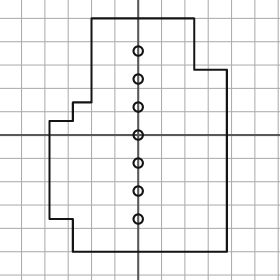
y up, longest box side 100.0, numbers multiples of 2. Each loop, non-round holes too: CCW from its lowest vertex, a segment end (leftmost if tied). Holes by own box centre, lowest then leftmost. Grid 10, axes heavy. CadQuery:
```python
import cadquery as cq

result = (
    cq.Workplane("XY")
    .moveTo(-28.0, -50.0)
    .lineTo(38.0, -50.0)
    .lineTo(38.0, 28.0)
    .lineTo(24.0, 28.0)
    .lineTo(24.0, 50.0)
    .lineTo(-20.0, 50.0)
    .lineTo(-20.0, 14.0)
    .lineTo(-28.0, 14.0)
    .lineTo(-28.0, 6.0)
    .lineTo(-38.0, 6.0)
    .lineTo(-38.0, -36.0)
    .lineTo(-28.0, -36.0)
    .close()
    .moveTo(0.0, -36.0)
    .circle(2.0)
    .moveTo(0.0, -24.0)
    .circle(2.0)
    .moveTo(0.0, -12.0)
    .circle(2.0)
    .moveTo(0.0, 0.0)
    .circle(2.0)
    .moveTo(0.0, 12.0)
    .circle(2.0)
    .moveTo(0.0, 24.0)
    .circle(2.0)
    .moveTo(0.0, 36.0)
    .circle(2.0)
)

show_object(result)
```